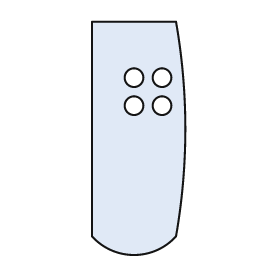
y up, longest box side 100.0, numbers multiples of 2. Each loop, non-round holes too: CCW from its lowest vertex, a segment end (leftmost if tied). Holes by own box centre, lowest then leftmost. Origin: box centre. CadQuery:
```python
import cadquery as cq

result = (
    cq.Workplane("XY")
    .moveTo(-20.0, -42.0)
    .threePointArc((-2.0, -50.0), (16.0, -42.0))
    .threePointArc((20.0, 4.0), (16.0, 50.0))
    .lineTo(-20.0, 50.0)
    .close()
    .moveTo(-2.0, 14.0)
    .circle(4.0)
    .moveTo(10.0, 14.0)
    .circle(4.0)
    .moveTo(-2.0, 26.0)
    .circle(4.0)
    .moveTo(10.0, 26.0)
    .circle(4.0)
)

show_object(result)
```